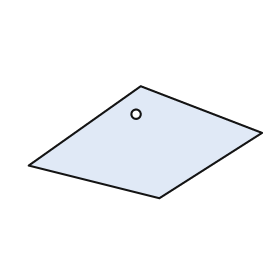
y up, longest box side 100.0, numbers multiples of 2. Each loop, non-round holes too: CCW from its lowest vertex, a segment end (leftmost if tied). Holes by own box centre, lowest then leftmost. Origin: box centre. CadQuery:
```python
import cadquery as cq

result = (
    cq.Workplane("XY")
    .moveTo(6.0, -24.0)
    .lineTo(50.0, 4.0)
    .lineTo(-2.0, 24.0)
    .lineTo(-50.0, -10.0)
    .close()
    .moveTo(-4.0, 12.0)
    .circle(2.0)
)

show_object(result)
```